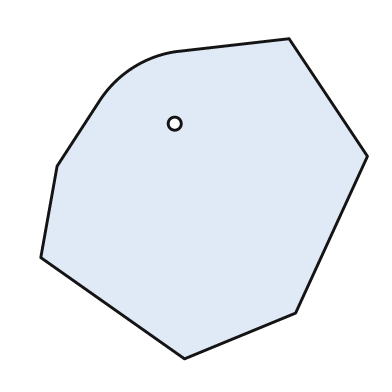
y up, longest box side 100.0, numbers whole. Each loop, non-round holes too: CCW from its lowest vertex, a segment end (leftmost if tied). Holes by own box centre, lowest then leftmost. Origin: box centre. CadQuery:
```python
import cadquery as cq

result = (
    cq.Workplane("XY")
    .moveTo(-6.0, -49.0)
    .lineTo(28.0, -35.0)
    .lineTo(50.0, 13.0)
    .lineTo(26.0, 49.0)
    .lineTo(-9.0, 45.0)
    .threePointArc((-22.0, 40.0), (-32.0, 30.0))
    .lineTo(-45.0, 10.0)
    .lineTo(-50.0, -18.0)
    .close()
    .moveTo(-9.0, 23.0)
    .circle(2.0)
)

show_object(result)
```